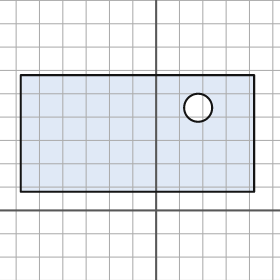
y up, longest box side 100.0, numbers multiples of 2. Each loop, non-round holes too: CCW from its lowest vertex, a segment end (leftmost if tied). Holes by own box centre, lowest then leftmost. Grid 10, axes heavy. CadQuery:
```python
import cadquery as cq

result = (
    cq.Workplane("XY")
    .moveTo(-58.0, 8.0)
    .lineTo(42.0, 8.0)
    .lineTo(42.0, 58.0)
    .lineTo(-58.0, 58.0)
    .close()
    .moveTo(18.0, 44.0)
    .circle(6.0)
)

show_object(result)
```